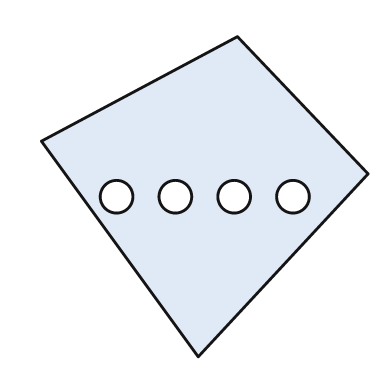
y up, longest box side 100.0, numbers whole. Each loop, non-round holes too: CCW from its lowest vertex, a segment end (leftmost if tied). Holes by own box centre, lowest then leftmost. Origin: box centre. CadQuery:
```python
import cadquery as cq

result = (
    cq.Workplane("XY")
    .moveTo(-2.0, -49.0)
    .lineTo(50.0, 7.0)
    .lineTo(10.0, 49.0)
    .lineTo(-50.0, 17.0)
    .close()
    .moveTo(-27.0, 0.0)
    .circle(5.0)
    .moveTo(-9.0, 0.0)
    .circle(5.0)
    .moveTo(9.0, 0.0)
    .circle(5.0)
    .moveTo(27.0, 0.0)
    .circle(5.0)
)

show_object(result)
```